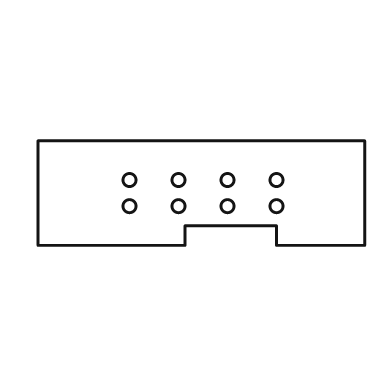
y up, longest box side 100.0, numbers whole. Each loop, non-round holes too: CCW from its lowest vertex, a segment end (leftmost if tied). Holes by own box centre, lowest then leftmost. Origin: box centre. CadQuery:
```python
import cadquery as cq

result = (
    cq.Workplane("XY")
    .moveTo(-50.0, -16.0)
    .lineTo(-5.0, -16.0)
    .lineTo(-5.0, -10.0)
    .lineTo(23.0, -10.0)
    .lineTo(23.0, -16.0)
    .lineTo(50.0, -16.0)
    .lineTo(50.0, 16.0)
    .lineTo(-50.0, 16.0)
    .close()
    .moveTo(-22.0, -4.0)
    .circle(2.0)
    .moveTo(-7.0, -4.0)
    .circle(2.0)
    .moveTo(8.0, -4.0)
    .circle(2.0)
    .moveTo(23.0, -4.0)
    .circle(2.0)
    .moveTo(-22.0, 4.0)
    .circle(2.0)
    .moveTo(-7.0, 4.0)
    .circle(2.0)
    .moveTo(8.0, 4.0)
    .circle(2.0)
    .moveTo(23.0, 4.0)
    .circle(2.0)
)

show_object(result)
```